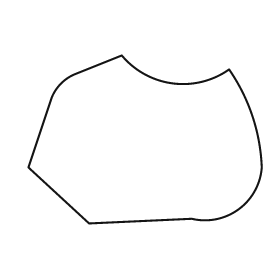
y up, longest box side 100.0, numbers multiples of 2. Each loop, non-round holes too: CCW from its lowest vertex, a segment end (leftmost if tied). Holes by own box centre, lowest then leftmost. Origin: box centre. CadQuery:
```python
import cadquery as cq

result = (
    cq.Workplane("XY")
    .moveTo(-24.0, -36.0)
    .lineTo(20.0, -34.0)
    .threePointArc((40.0, -30.0), (50.0, -12.0))
    .threePointArc((46.0, 10.0), (36.0, 30.0))
    .threePointArc((12.0, 24.0), (-10.0, 36.0))
    .lineTo(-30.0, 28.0)
    .threePointArc((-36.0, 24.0), (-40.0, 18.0))
    .lineTo(-50.0, -12.0)
    .close()
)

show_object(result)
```